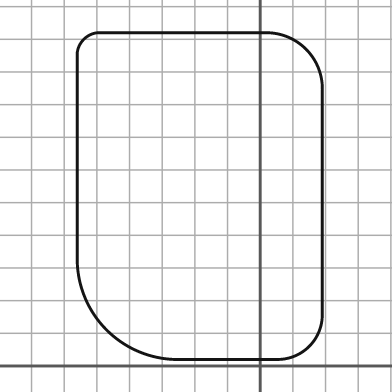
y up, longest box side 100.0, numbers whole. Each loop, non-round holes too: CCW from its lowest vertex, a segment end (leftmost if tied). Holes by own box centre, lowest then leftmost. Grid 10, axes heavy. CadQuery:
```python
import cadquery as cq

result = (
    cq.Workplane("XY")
    .moveTo(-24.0, 2.0)
    .lineTo(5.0, 2.0)
    .threePointArc((15.0, 6.0), (19.0, 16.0))
    .lineTo(19.0, 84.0)
    .threePointArc((14.0, 97.0), (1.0, 102.0))
    .lineTo(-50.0, 102.0)
    .threePointArc((-54.0, 100.0), (-56.0, 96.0))
    .lineTo(-56.0, 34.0)
    .threePointArc((-47.0, 11.0), (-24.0, 2.0))
    .close()
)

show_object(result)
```